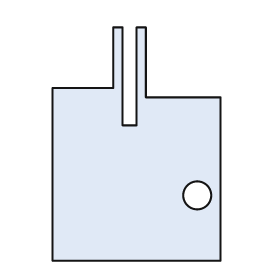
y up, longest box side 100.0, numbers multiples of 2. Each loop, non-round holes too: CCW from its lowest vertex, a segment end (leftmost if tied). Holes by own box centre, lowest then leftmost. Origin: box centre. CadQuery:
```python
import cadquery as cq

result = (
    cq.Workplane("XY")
    .moveTo(-36.0, -50.0)
    .lineTo(36.0, -50.0)
    .lineTo(36.0, 20.0)
    .lineTo(4.0, 20.0)
    .lineTo(4.0, 50.0)
    .lineTo(0.0, 50.0)
    .lineTo(0.0, 8.0)
    .lineTo(-6.0, 8.0)
    .lineTo(-6.0, 50.0)
    .lineTo(-10.0, 50.0)
    .lineTo(-10.0, 24.0)
    .lineTo(-36.0, 24.0)
    .close()
    .moveTo(26.0, -22.0)
    .circle(6.0)
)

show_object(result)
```